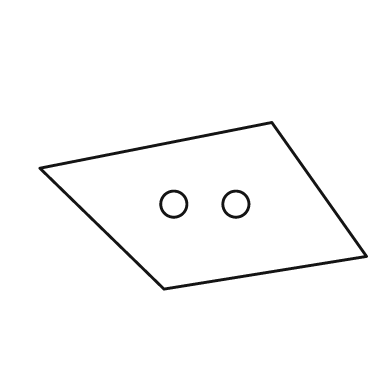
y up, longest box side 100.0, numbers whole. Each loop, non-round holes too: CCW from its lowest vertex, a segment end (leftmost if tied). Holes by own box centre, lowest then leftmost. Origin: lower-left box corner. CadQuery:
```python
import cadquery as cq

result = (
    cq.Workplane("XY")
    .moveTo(38.0, 0.0)
    .lineTo(100.0, 10.0)
    .lineTo(71.0, 51.0)
    .lineTo(0.0, 37.0)
    .close()
    .moveTo(41.0, 26.0)
    .circle(4.0)
    .moveTo(60.0, 26.0)
    .circle(4.0)
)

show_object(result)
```